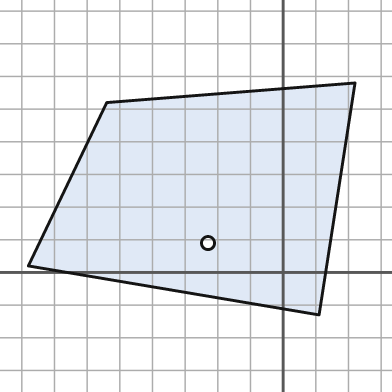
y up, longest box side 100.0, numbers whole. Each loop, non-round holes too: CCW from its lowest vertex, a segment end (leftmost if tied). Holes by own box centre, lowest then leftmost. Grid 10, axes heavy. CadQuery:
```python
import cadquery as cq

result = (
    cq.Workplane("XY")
    .moveTo(11.0, -13.0)
    .lineTo(22.0, 58.0)
    .lineTo(-54.0, 52.0)
    .lineTo(-78.0, 2.0)
    .close()
    .moveTo(-23.0, 9.0)
    .circle(2.0)
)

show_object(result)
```